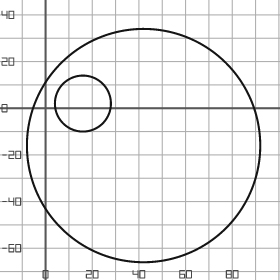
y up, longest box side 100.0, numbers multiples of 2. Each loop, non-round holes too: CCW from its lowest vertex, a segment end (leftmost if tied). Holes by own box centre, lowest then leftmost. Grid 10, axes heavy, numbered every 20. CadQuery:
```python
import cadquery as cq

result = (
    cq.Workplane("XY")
    .moveTo(42.0, -16.0)
    .circle(50.0)
    .moveTo(16.0, 2.0)
    .circle(12.0)
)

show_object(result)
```